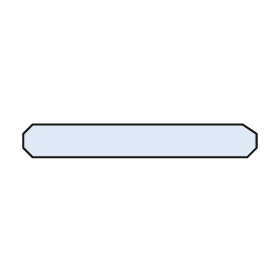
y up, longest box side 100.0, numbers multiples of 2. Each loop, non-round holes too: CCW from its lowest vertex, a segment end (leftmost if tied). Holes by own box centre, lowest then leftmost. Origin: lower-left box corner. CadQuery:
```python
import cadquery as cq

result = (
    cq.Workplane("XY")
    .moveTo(4.0, 0.0)
    .lineTo(96.0, 0.0)
    .lineTo(100.0, 4.0)
    .lineTo(100.0, 10.0)
    .lineTo(94.0, 14.0)
    .lineTo(4.0, 14.0)
    .lineTo(0.0, 10.0)
    .lineTo(0.0, 4.0)
    .close()
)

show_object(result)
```